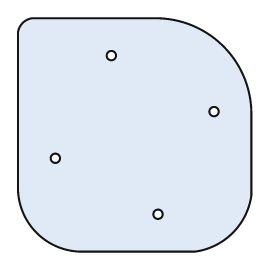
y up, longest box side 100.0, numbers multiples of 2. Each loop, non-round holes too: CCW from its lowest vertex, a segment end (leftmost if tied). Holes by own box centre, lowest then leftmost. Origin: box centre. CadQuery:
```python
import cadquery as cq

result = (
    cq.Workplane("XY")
    .moveTo(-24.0, -50.0)
    .lineTo(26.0, -50.0)
    .threePointArc((42.0, -42.0), (50.0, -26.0))
    .lineTo(50.0, 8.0)
    .threePointArc((38.0, 38.0), (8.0, 50.0))
    .lineTo(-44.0, 50.0)
    .threePointArc((-48.0, 48.0), (-50.0, 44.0))
    .lineTo(-50.0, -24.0)
    .threePointArc((-42.0, -42.0), (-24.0, -50.0))
    .close()
    .moveTo(10.0, -34.0)
    .circle(2.0)
    .moveTo(-34.0, -10.0)
    .circle(2.0)
    .moveTo(34.0, 10.0)
    .circle(2.0)
    .moveTo(-10.0, 34.0)
    .circle(2.0)
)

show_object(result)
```